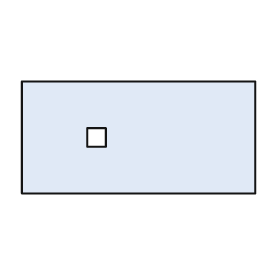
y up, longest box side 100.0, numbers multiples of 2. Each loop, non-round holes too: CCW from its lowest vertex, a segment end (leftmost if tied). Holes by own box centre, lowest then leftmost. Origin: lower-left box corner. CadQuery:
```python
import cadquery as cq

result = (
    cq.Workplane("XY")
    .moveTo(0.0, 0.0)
    .lineTo(100.0, 0.0)
    .lineTo(100.0, 48.0)
    .lineTo(0.0, 48.0)
    .close()
    .moveTo(28.0, 20.0)
    .lineTo(36.0, 20.0)
    .lineTo(36.0, 28.0)
    .lineTo(28.0, 28.0)
    .close()
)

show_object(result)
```